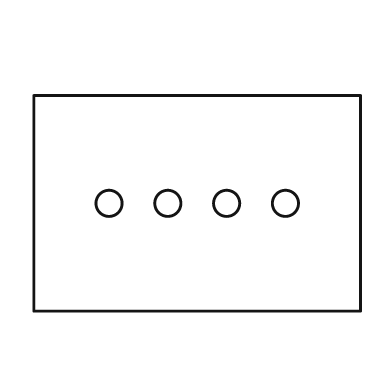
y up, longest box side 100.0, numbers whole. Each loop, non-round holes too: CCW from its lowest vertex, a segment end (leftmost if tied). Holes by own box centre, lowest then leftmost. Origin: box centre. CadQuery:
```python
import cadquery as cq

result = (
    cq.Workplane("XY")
    .moveTo(-50.0, -33.0)
    .lineTo(50.0, -33.0)
    .lineTo(50.0, 33.0)
    .lineTo(-50.0, 33.0)
    .close()
    .moveTo(-27.0, 0.0)
    .circle(4.0)
    .moveTo(-9.0, 0.0)
    .circle(4.0)
    .moveTo(9.0, 0.0)
    .circle(4.0)
    .moveTo(27.0, 0.0)
    .circle(4.0)
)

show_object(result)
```